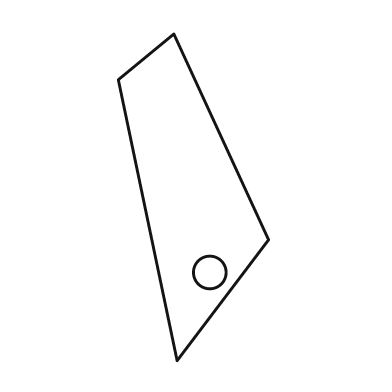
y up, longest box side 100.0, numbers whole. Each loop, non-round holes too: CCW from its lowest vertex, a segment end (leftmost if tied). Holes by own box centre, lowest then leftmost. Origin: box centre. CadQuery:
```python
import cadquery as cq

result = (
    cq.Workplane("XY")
    .moveTo(-5.0, -50.0)
    .lineTo(23.0, -13.0)
    .lineTo(-6.0, 50.0)
    .lineTo(-23.0, 36.0)
    .close()
    .moveTo(5.0, -23.0)
    .circle(5.0)
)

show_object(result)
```